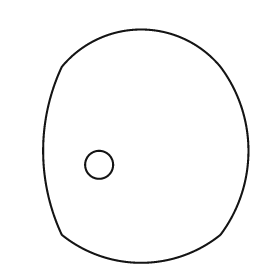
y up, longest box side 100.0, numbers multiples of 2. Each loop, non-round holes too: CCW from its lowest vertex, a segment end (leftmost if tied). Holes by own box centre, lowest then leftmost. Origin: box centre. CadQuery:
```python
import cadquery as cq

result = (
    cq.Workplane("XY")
    .moveTo(-36.0, -38.0)
    .threePointArc((-2.0, -50.0), (32.0, -38.0))
    .threePointArc((44.0, -2.0), (32.0, 34.0))
    .threePointArc((-2.0, 50.0), (-36.0, 34.0))
    .threePointArc((-44.0, -2.0), (-36.0, -38.0))
    .close()
    .moveTo(-20.0, -8.0)
    .circle(6.0)
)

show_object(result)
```